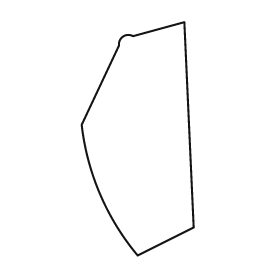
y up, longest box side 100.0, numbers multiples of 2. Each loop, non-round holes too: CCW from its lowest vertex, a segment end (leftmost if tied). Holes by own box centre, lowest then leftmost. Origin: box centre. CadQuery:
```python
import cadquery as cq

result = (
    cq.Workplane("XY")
    .moveTo(0.0, -50.0)
    .lineTo(24.0, -38.0)
    .lineTo(20.0, 50.0)
    .lineTo(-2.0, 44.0)
    .threePointArc((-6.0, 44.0), (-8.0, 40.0))
    .lineTo(-24.0, 6.0)
    .threePointArc((-16.0, -24.0), (0.0, -50.0))
    .close()
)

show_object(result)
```